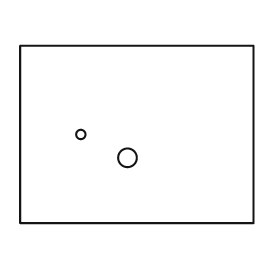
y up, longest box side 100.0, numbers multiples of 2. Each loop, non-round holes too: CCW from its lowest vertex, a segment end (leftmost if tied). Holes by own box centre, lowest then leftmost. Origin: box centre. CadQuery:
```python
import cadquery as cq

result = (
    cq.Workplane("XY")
    .moveTo(-50.0, -38.0)
    .lineTo(50.0, -38.0)
    .lineTo(50.0, 38.0)
    .lineTo(-50.0, 38.0)
    .close()
    .moveTo(-4.0, -10.0)
    .circle(4.0)
    .moveTo(-24.0, 0.0)
    .circle(2.0)
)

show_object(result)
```